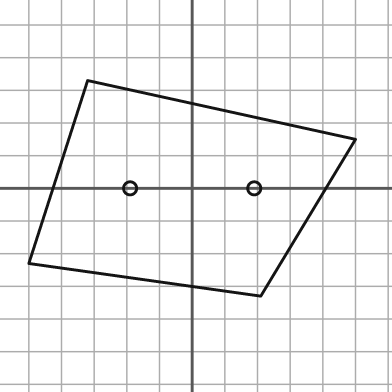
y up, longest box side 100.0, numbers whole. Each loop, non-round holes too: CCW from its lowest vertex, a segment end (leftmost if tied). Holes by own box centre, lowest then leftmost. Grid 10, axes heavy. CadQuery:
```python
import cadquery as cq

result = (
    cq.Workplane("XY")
    .moveTo(21.0, -33.0)
    .lineTo(50.0, 15.0)
    .lineTo(-32.0, 33.0)
    .lineTo(-50.0, -23.0)
    .close()
    .moveTo(-19.0, 0.0)
    .circle(2.0)
    .moveTo(19.0, 0.0)
    .circle(2.0)
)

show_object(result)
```